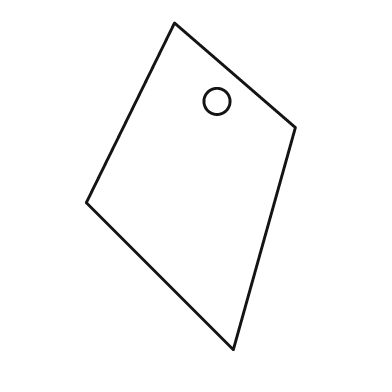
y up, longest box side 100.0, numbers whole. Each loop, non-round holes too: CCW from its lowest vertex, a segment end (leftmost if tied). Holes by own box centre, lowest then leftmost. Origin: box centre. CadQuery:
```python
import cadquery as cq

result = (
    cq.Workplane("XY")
    .moveTo(13.0, -50.0)
    .lineTo(32.0, 18.0)
    .lineTo(-5.0, 50.0)
    .lineTo(-32.0, -5.0)
    .close()
    .moveTo(8.0, 26.0)
    .circle(4.0)
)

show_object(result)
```